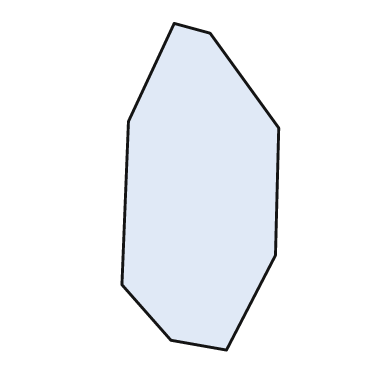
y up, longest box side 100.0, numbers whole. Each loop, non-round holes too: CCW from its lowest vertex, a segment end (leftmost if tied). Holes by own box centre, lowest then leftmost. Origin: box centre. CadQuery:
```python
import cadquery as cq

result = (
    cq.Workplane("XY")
    .moveTo(8.0, -50.0)
    .lineTo(23.0, -21.0)
    .lineTo(24.0, 18.0)
    .lineTo(3.0, 47.0)
    .lineTo(-8.0, 50.0)
    .lineTo(-22.0, 20.0)
    .lineTo(-24.0, -30.0)
    .lineTo(-9.0, -47.0)
    .close()
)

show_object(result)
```